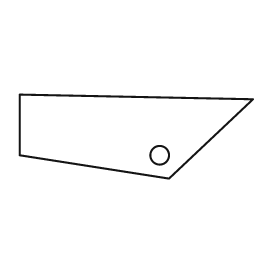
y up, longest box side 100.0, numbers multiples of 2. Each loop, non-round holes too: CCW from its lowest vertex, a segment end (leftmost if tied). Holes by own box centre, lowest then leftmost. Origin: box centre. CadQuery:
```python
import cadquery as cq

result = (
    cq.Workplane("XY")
    .moveTo(14.0, -18.0)
    .lineTo(50.0, 16.0)
    .lineTo(-50.0, 18.0)
    .lineTo(-50.0, -8.0)
    .close()
    .moveTo(10.0, -8.0)
    .circle(4.0)
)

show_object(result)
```